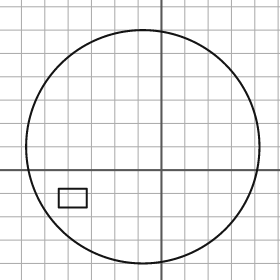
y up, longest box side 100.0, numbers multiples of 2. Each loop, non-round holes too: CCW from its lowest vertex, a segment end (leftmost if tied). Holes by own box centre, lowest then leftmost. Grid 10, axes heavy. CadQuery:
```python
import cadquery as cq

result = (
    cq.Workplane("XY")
    .moveTo(-8.0, 10.0)
    .circle(50.0)
    .moveTo(-44.0, -16.0)
    .lineTo(-32.0, -16.0)
    .lineTo(-32.0, -8.0)
    .lineTo(-44.0, -8.0)
    .close()
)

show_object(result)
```